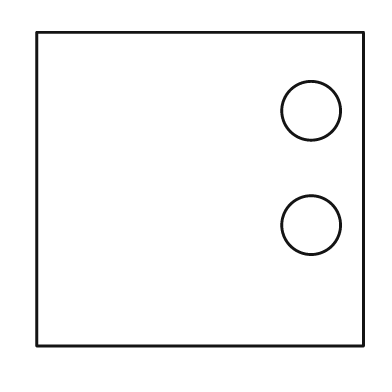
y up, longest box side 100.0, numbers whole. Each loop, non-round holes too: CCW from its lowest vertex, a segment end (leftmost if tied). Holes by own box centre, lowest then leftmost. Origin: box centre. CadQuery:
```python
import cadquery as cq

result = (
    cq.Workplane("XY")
    .moveTo(-50.0, -48.0)
    .lineTo(50.0, -48.0)
    .lineTo(50.0, 48.0)
    .lineTo(-50.0, 48.0)
    .close()
    .moveTo(34.0, -11.0)
    .circle(9.0)
    .moveTo(34.0, 24.0)
    .circle(9.0)
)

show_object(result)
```